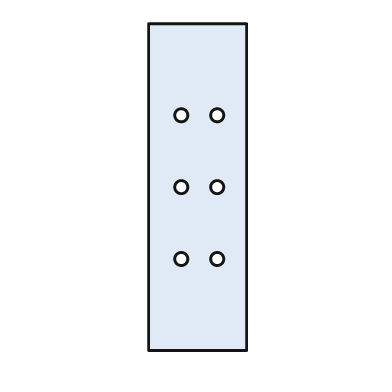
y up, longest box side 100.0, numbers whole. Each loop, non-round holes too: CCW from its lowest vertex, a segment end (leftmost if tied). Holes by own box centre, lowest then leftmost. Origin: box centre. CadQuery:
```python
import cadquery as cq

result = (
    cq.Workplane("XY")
    .moveTo(-15.0, -50.0)
    .lineTo(15.0, -50.0)
    .lineTo(15.0, 50.0)
    .lineTo(-15.0, 50.0)
    .close()
    .moveTo(-5.0, -22.0)
    .circle(2.0)
    .moveTo(6.0, -22.0)
    .circle(2.0)
    .moveTo(-5.0, 0.0)
    .circle(2.0)
    .moveTo(6.0, 0.0)
    .circle(2.0)
    .moveTo(-5.0, 22.0)
    .circle(2.0)
    .moveTo(6.0, 22.0)
    .circle(2.0)
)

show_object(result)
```